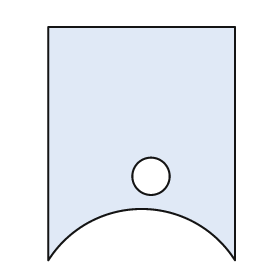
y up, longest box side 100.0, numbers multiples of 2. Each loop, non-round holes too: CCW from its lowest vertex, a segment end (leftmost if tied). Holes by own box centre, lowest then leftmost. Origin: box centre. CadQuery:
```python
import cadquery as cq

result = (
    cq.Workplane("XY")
    .moveTo(-40.0, -50.0)
    .threePointArc((0.0, -28.0), (40.0, -50.0))
    .lineTo(40.0, 50.0)
    .lineTo(-40.0, 50.0)
    .close()
    .moveTo(4.0, -14.0)
    .circle(8.0)
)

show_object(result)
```